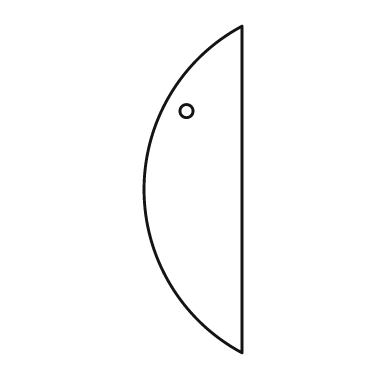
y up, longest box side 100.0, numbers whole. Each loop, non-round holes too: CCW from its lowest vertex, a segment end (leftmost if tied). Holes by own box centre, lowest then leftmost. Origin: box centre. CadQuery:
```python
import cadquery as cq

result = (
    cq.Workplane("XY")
    .moveTo(15.0, -50.0)
    .lineTo(15.0, 50.0)
    .threePointArc((-15.0, 0.0), (15.0, -50.0))
    .close()
    .moveTo(-2.0, 24.0)
    .circle(2.0)
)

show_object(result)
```